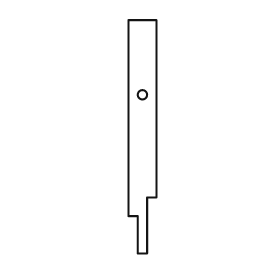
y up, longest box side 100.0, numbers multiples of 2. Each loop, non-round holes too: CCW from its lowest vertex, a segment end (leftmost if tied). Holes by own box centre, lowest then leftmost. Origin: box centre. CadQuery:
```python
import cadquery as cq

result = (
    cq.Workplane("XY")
    .moveTo(-2.0, -50.0)
    .lineTo(2.0, -50.0)
    .lineTo(2.0, -26.0)
    .lineTo(6.0, -26.0)
    .lineTo(6.0, 50.0)
    .lineTo(-6.0, 50.0)
    .lineTo(-6.0, -34.0)
    .lineTo(-2.0, -34.0)
    .close()
    .moveTo(0.0, 18.0)
    .circle(2.0)
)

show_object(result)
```